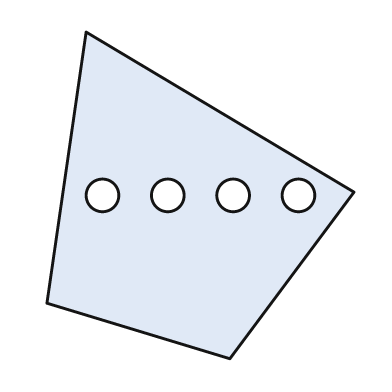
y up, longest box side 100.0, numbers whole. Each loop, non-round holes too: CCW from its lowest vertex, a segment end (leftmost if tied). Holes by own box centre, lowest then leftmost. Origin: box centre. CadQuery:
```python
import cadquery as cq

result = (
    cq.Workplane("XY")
    .moveTo(9.0, -50.0)
    .lineTo(47.0, 1.0)
    .lineTo(-35.0, 50.0)
    .lineTo(-47.0, -33.0)
    .close()
    .moveTo(-30.0, 0.0)
    .circle(5.0)
    .moveTo(-10.0, 0.0)
    .circle(5.0)
    .moveTo(10.0, 0.0)
    .circle(5.0)
    .moveTo(30.0, 0.0)
    .circle(5.0)
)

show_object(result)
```